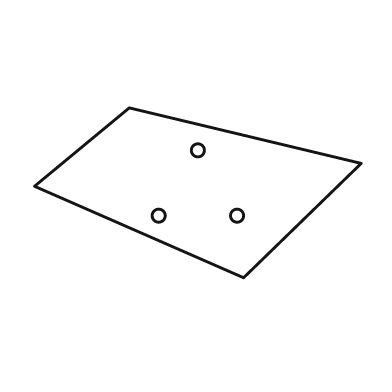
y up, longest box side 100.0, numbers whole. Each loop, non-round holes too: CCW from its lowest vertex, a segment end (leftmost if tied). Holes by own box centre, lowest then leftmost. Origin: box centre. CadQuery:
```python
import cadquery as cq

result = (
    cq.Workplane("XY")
    .moveTo(14.0, -26.0)
    .lineTo(50.0, 9.0)
    .lineTo(-21.0, 26.0)
    .lineTo(-50.0, 2.0)
    .close()
    .moveTo(-12.0, -7.0)
    .circle(2.0)
    .moveTo(12.0, -7.0)
    .circle(2.0)
    .moveTo(0.0, 13.0)
    .circle(2.0)
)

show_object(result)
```